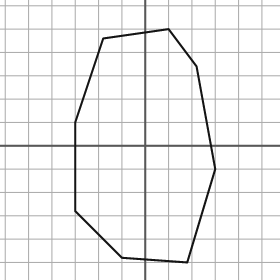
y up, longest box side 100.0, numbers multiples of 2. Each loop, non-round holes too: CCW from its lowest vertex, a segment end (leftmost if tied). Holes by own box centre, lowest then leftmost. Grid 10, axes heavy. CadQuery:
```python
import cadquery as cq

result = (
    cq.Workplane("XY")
    .moveTo(18.0, -50.0)
    .lineTo(30.0, -10.0)
    .lineTo(22.0, 34.0)
    .lineTo(10.0, 50.0)
    .lineTo(-18.0, 46.0)
    .lineTo(-30.0, 10.0)
    .lineTo(-30.0, -28.0)
    .lineTo(-10.0, -48.0)
    .close()
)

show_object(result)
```